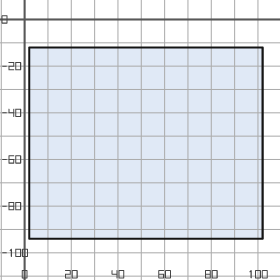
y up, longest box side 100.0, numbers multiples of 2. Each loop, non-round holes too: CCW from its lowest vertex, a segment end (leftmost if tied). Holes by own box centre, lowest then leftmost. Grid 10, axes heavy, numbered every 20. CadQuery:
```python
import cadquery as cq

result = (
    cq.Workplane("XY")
    .moveTo(2.0, -94.0)
    .lineTo(102.0, -94.0)
    .lineTo(102.0, -12.0)
    .lineTo(2.0, -12.0)
    .close()
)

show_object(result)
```